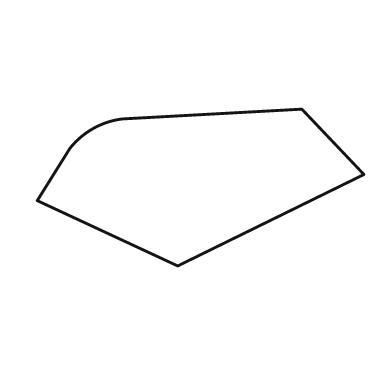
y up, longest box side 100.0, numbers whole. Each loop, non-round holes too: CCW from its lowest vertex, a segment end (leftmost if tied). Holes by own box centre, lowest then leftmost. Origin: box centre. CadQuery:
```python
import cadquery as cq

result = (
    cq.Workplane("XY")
    .moveTo(-7.0, -24.0)
    .lineTo(50.0, 4.0)
    .lineTo(31.0, 24.0)
    .lineTo(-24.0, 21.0)
    .threePointArc((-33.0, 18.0), (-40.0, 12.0))
    .lineTo(-50.0, -4.0)
    .close()
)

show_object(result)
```